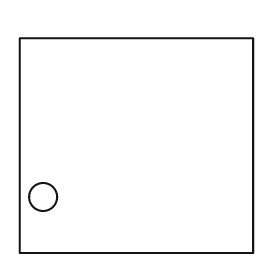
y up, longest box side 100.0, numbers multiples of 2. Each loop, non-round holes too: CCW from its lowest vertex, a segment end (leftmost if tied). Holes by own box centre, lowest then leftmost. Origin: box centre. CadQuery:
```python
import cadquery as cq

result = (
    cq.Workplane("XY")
    .moveTo(-50.0, -46.0)
    .lineTo(50.0, -46.0)
    .lineTo(50.0, 46.0)
    .lineTo(-50.0, 46.0)
    .close()
    .moveTo(-40.0, -22.0)
    .circle(6.0)
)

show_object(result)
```